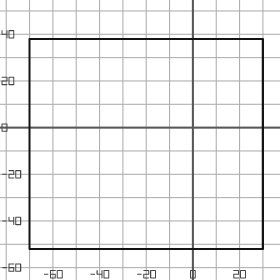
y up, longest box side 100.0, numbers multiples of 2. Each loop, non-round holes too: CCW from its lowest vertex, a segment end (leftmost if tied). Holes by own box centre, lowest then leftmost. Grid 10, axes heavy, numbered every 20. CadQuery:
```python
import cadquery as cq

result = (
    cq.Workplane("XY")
    .moveTo(-70.0, -52.0)
    .lineTo(30.0, -52.0)
    .lineTo(30.0, 38.0)
    .lineTo(-70.0, 38.0)
    .close()
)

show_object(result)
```